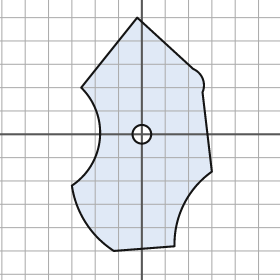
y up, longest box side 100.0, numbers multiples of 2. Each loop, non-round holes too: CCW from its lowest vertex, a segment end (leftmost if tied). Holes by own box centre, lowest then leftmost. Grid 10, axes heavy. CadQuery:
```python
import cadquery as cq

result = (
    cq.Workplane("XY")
    .moveTo(-12.0, -50.0)
    .lineTo(14.0, -48.0)
    .threePointArc((18.0, -30.0), (30.0, -16.0))
    .lineTo(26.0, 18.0)
    .threePointArc((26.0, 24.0), (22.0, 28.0))
    .lineTo(-2.0, 50.0)
    .lineTo(-26.0, 20.0)
    .threePointArc((-18.0, -2.0), (-30.0, -22.0))
    .threePointArc((-24.0, -38.0), (-12.0, -50.0))
    .close()
    .moveTo(0.0, 0.0)
    .circle(4.0)
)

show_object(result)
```